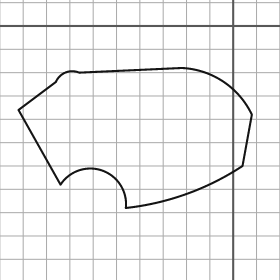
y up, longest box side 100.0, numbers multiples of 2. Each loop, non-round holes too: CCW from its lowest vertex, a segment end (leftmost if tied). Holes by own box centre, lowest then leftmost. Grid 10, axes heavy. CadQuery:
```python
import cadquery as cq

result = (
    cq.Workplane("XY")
    .moveTo(-46.0, -78.0)
    .threePointArc((-20.0, -72.0), (4.0, -60.0))
    .lineTo(8.0, -38.0)
    .threePointArc((-4.0, -24.0), (-22.0, -18.0))
    .lineTo(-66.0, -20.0)
    .threePointArc((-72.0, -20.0), (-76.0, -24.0))
    .lineTo(-92.0, -36.0)
    .lineTo(-74.0, -68.0)
    .threePointArc((-56.0, -62.0), (-46.0, -78.0))
    .close()
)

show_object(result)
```